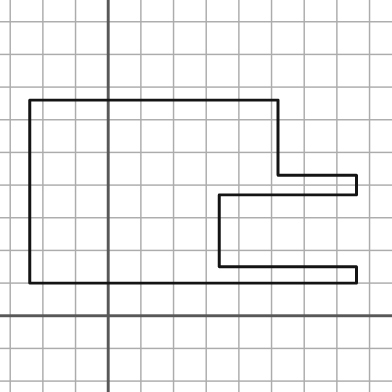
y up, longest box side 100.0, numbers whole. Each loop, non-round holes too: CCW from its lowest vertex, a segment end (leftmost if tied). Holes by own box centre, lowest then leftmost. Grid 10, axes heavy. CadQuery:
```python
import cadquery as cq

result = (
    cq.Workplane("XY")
    .moveTo(-24.0, 10.0)
    .lineTo(76.0, 10.0)
    .lineTo(76.0, 15.0)
    .lineTo(34.0, 15.0)
    .lineTo(34.0, 37.0)
    .lineTo(76.0, 37.0)
    .lineTo(76.0, 43.0)
    .lineTo(52.0, 43.0)
    .lineTo(52.0, 66.0)
    .lineTo(-24.0, 66.0)
    .close()
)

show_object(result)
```